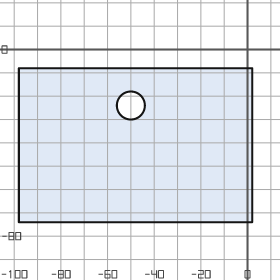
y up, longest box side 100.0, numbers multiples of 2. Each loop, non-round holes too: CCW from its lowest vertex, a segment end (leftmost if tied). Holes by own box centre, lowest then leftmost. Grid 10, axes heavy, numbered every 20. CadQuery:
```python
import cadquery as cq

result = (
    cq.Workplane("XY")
    .moveTo(-98.0, -74.0)
    .lineTo(2.0, -74.0)
    .lineTo(2.0, -8.0)
    .lineTo(-98.0, -8.0)
    .close()
    .moveTo(-50.0, -24.0)
    .circle(6.0)
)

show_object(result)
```